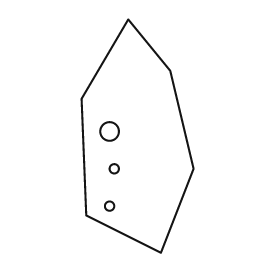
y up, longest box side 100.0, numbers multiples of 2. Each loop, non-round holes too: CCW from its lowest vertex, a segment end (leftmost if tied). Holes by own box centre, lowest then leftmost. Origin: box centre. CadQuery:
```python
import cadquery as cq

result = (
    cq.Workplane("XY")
    .moveTo(10.0, -50.0)
    .lineTo(24.0, -14.0)
    .lineTo(14.0, 28.0)
    .lineTo(-4.0, 50.0)
    .lineTo(-24.0, 16.0)
    .lineTo(-22.0, -34.0)
    .close()
    .moveTo(-12.0, -30.0)
    .circle(2.0)
    .moveTo(-10.0, -14.0)
    .circle(2.0)
    .moveTo(-12.0, 2.0)
    .circle(4.0)
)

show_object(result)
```